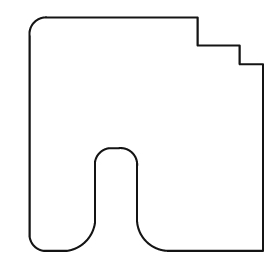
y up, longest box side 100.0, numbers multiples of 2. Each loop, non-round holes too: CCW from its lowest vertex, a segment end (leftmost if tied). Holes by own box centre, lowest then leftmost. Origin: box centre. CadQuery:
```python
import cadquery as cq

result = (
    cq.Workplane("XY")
    .moveTo(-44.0, -50.0)
    .lineTo(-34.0, -50.0)
    .threePointArc((-26.0, -46.0), (-22.0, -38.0))
    .lineTo(-22.0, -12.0)
    .threePointArc((-20.0, -8.0), (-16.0, -6.0))
    .lineTo(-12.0, -6.0)
    .threePointArc((-6.0, -8.0), (-4.0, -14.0))
    .lineTo(-4.0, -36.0)
    .threePointArc((0.0, -46.0), (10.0, -50.0))
    .lineTo(50.0, -50.0)
    .lineTo(50.0, 30.0)
    .lineTo(40.0, 30.0)
    .lineTo(40.0, 38.0)
    .lineTo(22.0, 38.0)
    .lineTo(22.0, 50.0)
    .lineTo(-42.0, 50.0)
    .threePointArc((-48.0, 48.0), (-50.0, 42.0))
    .lineTo(-50.0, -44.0)
    .threePointArc((-48.0, -48.0), (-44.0, -50.0))
    .close()
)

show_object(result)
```